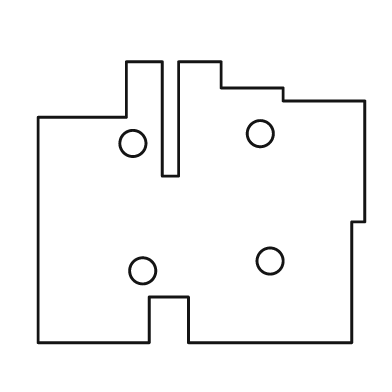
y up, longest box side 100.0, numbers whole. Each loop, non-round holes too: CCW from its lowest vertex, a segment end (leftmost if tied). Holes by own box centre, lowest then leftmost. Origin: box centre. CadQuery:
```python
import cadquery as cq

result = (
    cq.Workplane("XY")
    .moveTo(-50.0, -43.0)
    .lineTo(-16.0, -43.0)
    .lineTo(-16.0, -29.0)
    .lineTo(-4.0, -29.0)
    .lineTo(-4.0, -43.0)
    .lineTo(46.0, -43.0)
    .lineTo(46.0, -6.0)
    .lineTo(50.0, -6.0)
    .lineTo(50.0, 31.0)
    .lineTo(25.0, 31.0)
    .lineTo(25.0, 35.0)
    .lineTo(6.0, 35.0)
    .lineTo(6.0, 43.0)
    .lineTo(-7.0, 43.0)
    .lineTo(-7.0, 8.0)
    .lineTo(-12.0, 8.0)
    .lineTo(-12.0, 43.0)
    .lineTo(-23.0, 43.0)
    .lineTo(-23.0, 26.0)
    .lineTo(-50.0, 26.0)
    .close()
    .moveTo(-18.0, -21.0)
    .circle(4.0)
    .moveTo(21.0, -18.0)
    .circle(4.0)
    .moveTo(-21.0, 18.0)
    .circle(4.0)
    .moveTo(18.0, 21.0)
    .circle(4.0)
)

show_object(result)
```